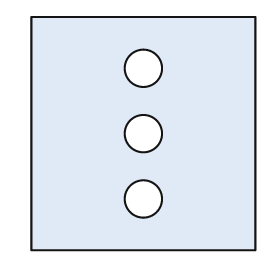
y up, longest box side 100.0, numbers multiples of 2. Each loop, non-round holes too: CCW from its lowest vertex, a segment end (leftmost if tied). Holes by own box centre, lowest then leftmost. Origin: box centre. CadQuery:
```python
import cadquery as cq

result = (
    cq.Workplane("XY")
    .moveTo(-48.0, -50.0)
    .lineTo(48.0, -50.0)
    .lineTo(48.0, 50.0)
    .lineTo(-48.0, 50.0)
    .close()
    .moveTo(0.0, -28.0)
    .circle(8.0)
    .moveTo(0.0, 0.0)
    .circle(8.0)
    .moveTo(0.0, 28.0)
    .circle(8.0)
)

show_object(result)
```